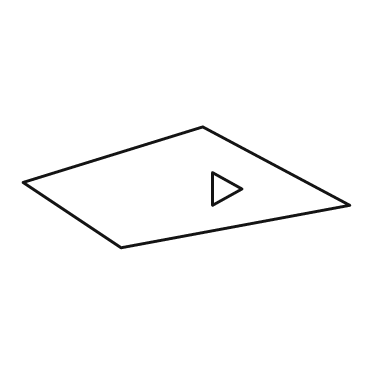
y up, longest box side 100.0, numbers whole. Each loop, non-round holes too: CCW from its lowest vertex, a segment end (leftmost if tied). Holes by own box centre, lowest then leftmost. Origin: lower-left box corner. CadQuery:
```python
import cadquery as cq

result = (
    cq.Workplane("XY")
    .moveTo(30.0, 0.0)
    .lineTo(100.0, 13.0)
    .lineTo(55.0, 37.0)
    .lineTo(0.0, 20.0)
    .close()
    .moveTo(58.0, 13.0)
    .lineTo(67.0, 18.0)
    .lineTo(58.0, 23.0)
    .close()
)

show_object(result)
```